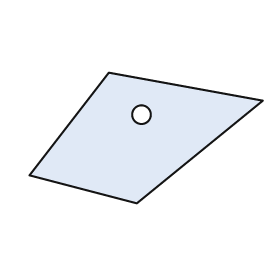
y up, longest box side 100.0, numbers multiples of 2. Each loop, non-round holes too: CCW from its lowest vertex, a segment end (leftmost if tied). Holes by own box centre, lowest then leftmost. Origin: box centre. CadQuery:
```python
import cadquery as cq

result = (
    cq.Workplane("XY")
    .moveTo(-4.0, -28.0)
    .lineTo(50.0, 16.0)
    .lineTo(-16.0, 28.0)
    .lineTo(-50.0, -16.0)
    .close()
    .moveTo(-2.0, 10.0)
    .circle(4.0)
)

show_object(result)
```